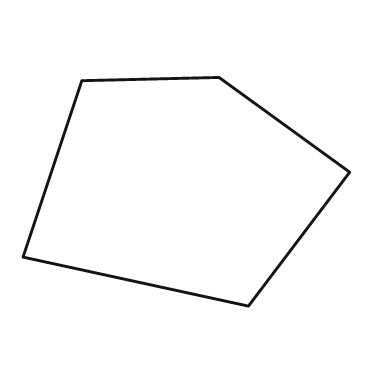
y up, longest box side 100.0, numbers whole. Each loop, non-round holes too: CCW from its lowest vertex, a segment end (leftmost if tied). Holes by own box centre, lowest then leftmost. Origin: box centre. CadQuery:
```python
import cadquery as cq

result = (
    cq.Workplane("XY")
    .moveTo(19.0, -35.0)
    .lineTo(50.0, 6.0)
    .lineTo(10.0, 35.0)
    .lineTo(-32.0, 34.0)
    .lineTo(-50.0, -20.0)
    .close()
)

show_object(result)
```